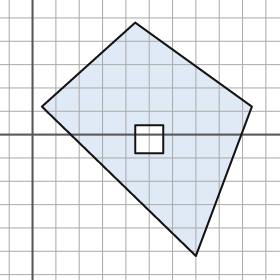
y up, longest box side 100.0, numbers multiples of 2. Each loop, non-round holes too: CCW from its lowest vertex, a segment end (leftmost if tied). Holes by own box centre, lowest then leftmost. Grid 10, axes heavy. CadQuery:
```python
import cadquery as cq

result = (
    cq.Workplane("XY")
    .moveTo(70.0, -52.0)
    .lineTo(94.0, 12.0)
    .lineTo(44.0, 48.0)
    .lineTo(4.0, 12.0)
    .close()
    .moveTo(44.0, -8.0)
    .lineTo(56.0, -8.0)
    .lineTo(56.0, 4.0)
    .lineTo(44.0, 4.0)
    .close()
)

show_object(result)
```